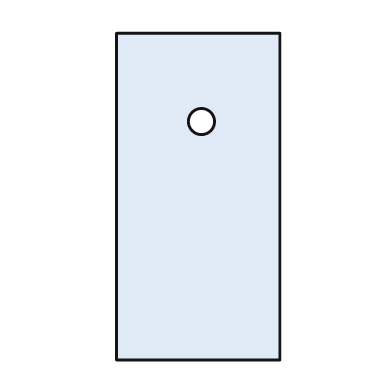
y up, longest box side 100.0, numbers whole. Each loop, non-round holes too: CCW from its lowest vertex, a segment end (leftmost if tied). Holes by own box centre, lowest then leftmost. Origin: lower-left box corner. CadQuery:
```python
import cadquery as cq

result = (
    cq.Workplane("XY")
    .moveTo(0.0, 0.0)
    .lineTo(50.0, 0.0)
    .lineTo(50.0, 100.0)
    .lineTo(0.0, 100.0)
    .close()
    .moveTo(26.0, 73.0)
    .circle(4.0)
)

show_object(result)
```